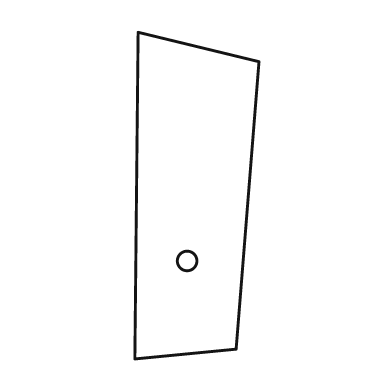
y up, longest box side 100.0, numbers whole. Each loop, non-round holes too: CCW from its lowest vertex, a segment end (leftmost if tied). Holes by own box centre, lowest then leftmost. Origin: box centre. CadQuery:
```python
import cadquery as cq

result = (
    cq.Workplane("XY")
    .moveTo(-19.0, -50.0)
    .lineTo(12.0, -47.0)
    .lineTo(19.0, 41.0)
    .lineTo(-18.0, 50.0)
    .close()
    .moveTo(-3.0, -20.0)
    .circle(3.0)
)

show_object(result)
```